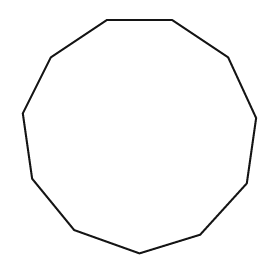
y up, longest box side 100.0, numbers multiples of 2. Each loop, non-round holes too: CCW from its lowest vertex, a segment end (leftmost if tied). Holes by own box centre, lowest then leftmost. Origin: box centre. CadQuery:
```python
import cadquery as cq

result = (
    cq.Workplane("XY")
    .moveTo(0.0, -50.0)
    .lineTo(26.0, -42.0)
    .lineTo(46.0, -20.0)
    .lineTo(50.0, 8.0)
    .lineTo(38.0, 34.0)
    .lineTo(14.0, 50.0)
    .lineTo(-14.0, 50.0)
    .lineTo(-38.0, 34.0)
    .lineTo(-50.0, 10.0)
    .lineTo(-46.0, -18.0)
    .lineTo(-28.0, -40.0)
    .close()
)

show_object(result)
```